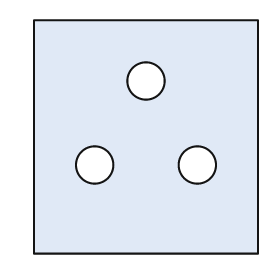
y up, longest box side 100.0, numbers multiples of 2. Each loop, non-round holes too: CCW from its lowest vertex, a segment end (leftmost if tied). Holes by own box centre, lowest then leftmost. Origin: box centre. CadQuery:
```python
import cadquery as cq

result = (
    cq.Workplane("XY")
    .moveTo(-48.0, -50.0)
    .lineTo(48.0, -50.0)
    .lineTo(48.0, 50.0)
    .lineTo(-48.0, 50.0)
    .close()
    .moveTo(-22.0, -12.0)
    .circle(8.0)
    .moveTo(22.0, -12.0)
    .circle(8.0)
    .moveTo(0.0, 24.0)
    .circle(8.0)
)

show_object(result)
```